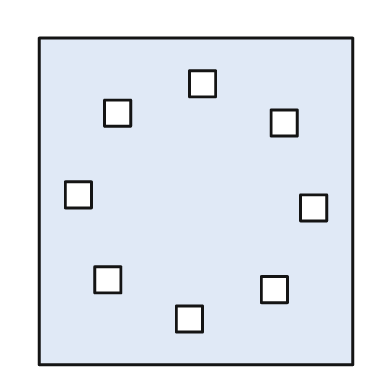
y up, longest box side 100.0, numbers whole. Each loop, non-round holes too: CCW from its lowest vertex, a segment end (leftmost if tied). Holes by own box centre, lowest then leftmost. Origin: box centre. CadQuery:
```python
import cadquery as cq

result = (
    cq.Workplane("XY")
    .moveTo(-48.0, -50.0)
    .lineTo(48.0, -50.0)
    .lineTo(48.0, 50.0)
    .lineTo(-48.0, 50.0)
    .close()
    .moveTo(-6.0, -40.0)
    .lineTo(2.0, -40.0)
    .lineTo(2.0, -32.0)
    .lineTo(-6.0, -32.0)
    .close()
    .moveTo(20.0, -31.0)
    .lineTo(28.0, -31.0)
    .lineTo(28.0, -23.0)
    .lineTo(20.0, -23.0)
    .close()
    .moveTo(-31.0, -28.0)
    .lineTo(-23.0, -28.0)
    .lineTo(-23.0, -20.0)
    .lineTo(-31.0, -20.0)
    .close()
    .moveTo(32.0, -6.0)
    .lineTo(40.0, -6.0)
    .lineTo(40.0, 2.0)
    .lineTo(32.0, 2.0)
    .close()
    .moveTo(-40.0, -2.0)
    .lineTo(-32.0, -2.0)
    .lineTo(-32.0, 6.0)
    .lineTo(-40.0, 6.0)
    .close()
    .moveTo(23.0, 20.0)
    .lineTo(31.0, 20.0)
    .lineTo(31.0, 28.0)
    .lineTo(23.0, 28.0)
    .close()
    .moveTo(-28.0, 23.0)
    .lineTo(-20.0, 23.0)
    .lineTo(-20.0, 31.0)
    .lineTo(-28.0, 31.0)
    .close()
    .moveTo(-2.0, 32.0)
    .lineTo(6.0, 32.0)
    .lineTo(6.0, 40.0)
    .lineTo(-2.0, 40.0)
    .close()
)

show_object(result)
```